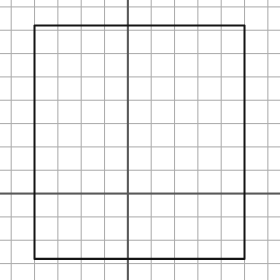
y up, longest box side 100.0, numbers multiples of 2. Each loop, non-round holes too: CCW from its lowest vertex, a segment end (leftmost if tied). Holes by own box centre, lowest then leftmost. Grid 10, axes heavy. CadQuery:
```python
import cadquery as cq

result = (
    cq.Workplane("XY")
    .moveTo(-40.0, -28.0)
    .lineTo(50.0, -28.0)
    .lineTo(50.0, 72.0)
    .lineTo(-40.0, 72.0)
    .close()
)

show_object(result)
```